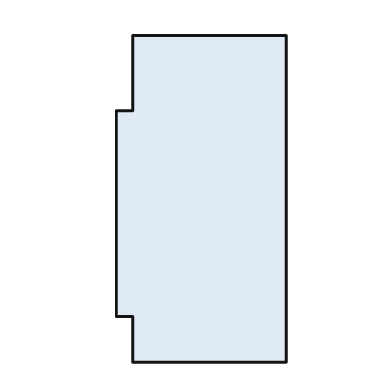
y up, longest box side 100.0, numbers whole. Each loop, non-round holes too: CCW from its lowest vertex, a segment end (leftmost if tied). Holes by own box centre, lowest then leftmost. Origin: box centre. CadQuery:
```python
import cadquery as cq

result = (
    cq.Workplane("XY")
    .moveTo(-21.0, -50.0)
    .lineTo(26.0, -50.0)
    .lineTo(26.0, 50.0)
    .lineTo(-21.0, 50.0)
    .lineTo(-21.0, 27.0)
    .lineTo(-26.0, 27.0)
    .lineTo(-26.0, -36.0)
    .lineTo(-21.0, -36.0)
    .close()
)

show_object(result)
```